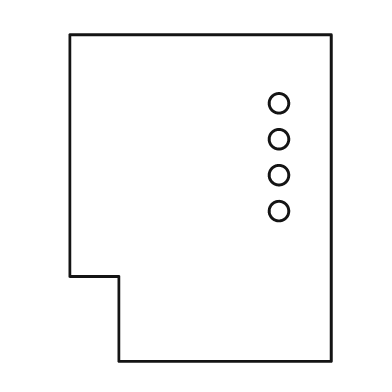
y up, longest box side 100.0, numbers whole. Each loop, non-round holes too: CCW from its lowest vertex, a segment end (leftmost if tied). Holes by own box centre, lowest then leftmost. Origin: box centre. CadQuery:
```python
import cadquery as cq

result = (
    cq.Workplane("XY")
    .moveTo(-25.0, -50.0)
    .lineTo(40.0, -50.0)
    .lineTo(40.0, 50.0)
    .lineTo(-40.0, 50.0)
    .lineTo(-40.0, -24.0)
    .lineTo(-25.0, -24.0)
    .close()
    .moveTo(24.0, -4.0)
    .circle(3.0)
    .moveTo(24.0, 7.0)
    .circle(3.0)
    .moveTo(24.0, 18.0)
    .circle(3.0)
    .moveTo(24.0, 29.0)
    .circle(3.0)
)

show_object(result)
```